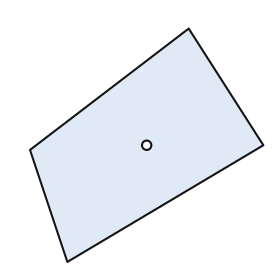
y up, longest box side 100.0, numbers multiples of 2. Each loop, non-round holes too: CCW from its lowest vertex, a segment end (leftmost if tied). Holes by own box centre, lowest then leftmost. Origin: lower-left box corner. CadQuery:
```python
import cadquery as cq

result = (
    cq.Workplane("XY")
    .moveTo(16.0, 0.0)
    .lineTo(100.0, 50.0)
    .lineTo(68.0, 100.0)
    .lineTo(0.0, 48.0)
    .close()
    .moveTo(50.0, 50.0)
    .circle(2.0)
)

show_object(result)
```